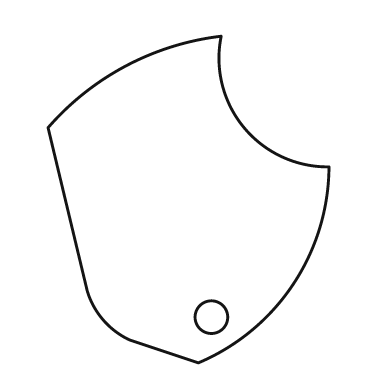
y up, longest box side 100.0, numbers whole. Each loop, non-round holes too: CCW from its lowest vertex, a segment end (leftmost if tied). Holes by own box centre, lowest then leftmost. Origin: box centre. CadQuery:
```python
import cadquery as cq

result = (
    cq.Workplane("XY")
    .moveTo(3.0, -50.0)
    .threePointArc((32.0, -26.0), (43.0, 10.0))
    .threePointArc((17.0, 22.0), (10.0, 50.0))
    .threePointArc((-19.0, 41.0), (-43.0, 22.0))
    .lineTo(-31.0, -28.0)
    .threePointArc((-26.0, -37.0), (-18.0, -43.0))
    .close()
    .moveTo(7.0, -36.0)
    .circle(5.0)
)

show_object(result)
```